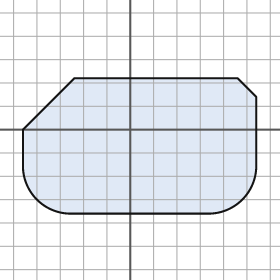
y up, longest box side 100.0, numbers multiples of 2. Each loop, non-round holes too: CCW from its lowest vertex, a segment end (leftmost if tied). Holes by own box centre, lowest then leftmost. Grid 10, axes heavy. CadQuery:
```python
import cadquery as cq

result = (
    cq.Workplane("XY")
    .moveTo(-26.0, -36.0)
    .lineTo(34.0, -36.0)
    .threePointArc((48.0, -30.0), (54.0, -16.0))
    .lineTo(54.0, 14.0)
    .lineTo(46.0, 22.0)
    .lineTo(-24.0, 22.0)
    .lineTo(-46.0, 0.0)
    .lineTo(-46.0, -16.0)
    .threePointArc((-40.0, -30.0), (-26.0, -36.0))
    .close()
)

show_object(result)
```